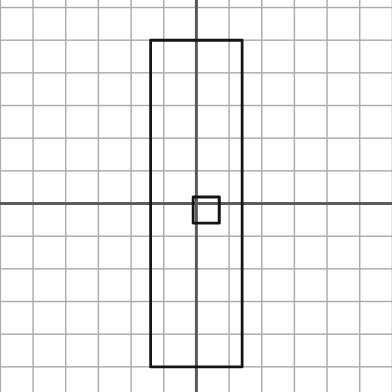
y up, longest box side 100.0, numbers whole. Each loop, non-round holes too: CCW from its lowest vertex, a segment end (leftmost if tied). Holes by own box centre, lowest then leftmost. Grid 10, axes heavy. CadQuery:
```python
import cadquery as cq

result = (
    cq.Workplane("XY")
    .moveTo(-14.0, -50.0)
    .lineTo(14.0, -50.0)
    .lineTo(14.0, 50.0)
    .lineTo(-14.0, 50.0)
    .close()
    .moveTo(-1.0, -6.0)
    .lineTo(7.0, -6.0)
    .lineTo(7.0, 2.0)
    .lineTo(-1.0, 2.0)
    .close()
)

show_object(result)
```